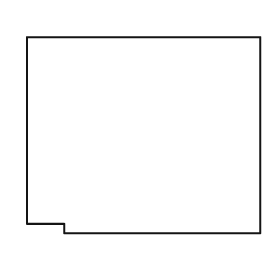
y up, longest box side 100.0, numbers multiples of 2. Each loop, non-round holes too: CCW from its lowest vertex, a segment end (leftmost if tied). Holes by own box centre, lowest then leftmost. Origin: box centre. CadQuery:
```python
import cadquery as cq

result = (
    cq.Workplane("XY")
    .moveTo(-34.0, -42.0)
    .lineTo(50.0, -42.0)
    .lineTo(50.0, 42.0)
    .lineTo(-50.0, 42.0)
    .lineTo(-50.0, -38.0)
    .lineTo(-34.0, -38.0)
    .close()
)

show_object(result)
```